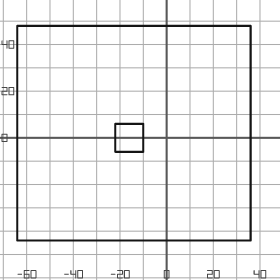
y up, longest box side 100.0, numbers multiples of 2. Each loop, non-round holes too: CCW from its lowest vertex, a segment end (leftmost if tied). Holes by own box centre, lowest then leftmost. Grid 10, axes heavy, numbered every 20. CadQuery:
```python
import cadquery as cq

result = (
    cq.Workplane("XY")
    .moveTo(-64.0, -44.0)
    .lineTo(36.0, -44.0)
    .lineTo(36.0, 48.0)
    .lineTo(-64.0, 48.0)
    .close()
    .moveTo(-22.0, -6.0)
    .lineTo(-10.0, -6.0)
    .lineTo(-10.0, 6.0)
    .lineTo(-22.0, 6.0)
    .close()
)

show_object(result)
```